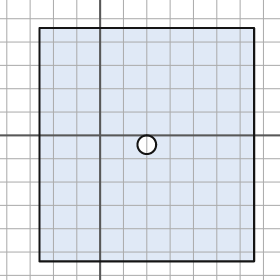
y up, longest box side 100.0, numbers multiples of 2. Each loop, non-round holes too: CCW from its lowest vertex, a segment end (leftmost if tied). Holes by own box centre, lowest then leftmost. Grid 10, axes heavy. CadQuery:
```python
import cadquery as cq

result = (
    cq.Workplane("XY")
    .moveTo(-26.0, -54.0)
    .lineTo(66.0, -54.0)
    .lineTo(66.0, 46.0)
    .lineTo(-26.0, 46.0)
    .close()
    .moveTo(20.0, -4.0)
    .circle(4.0)
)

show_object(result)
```